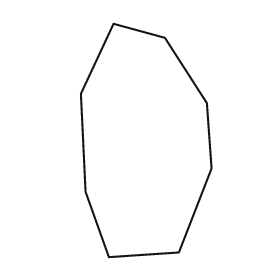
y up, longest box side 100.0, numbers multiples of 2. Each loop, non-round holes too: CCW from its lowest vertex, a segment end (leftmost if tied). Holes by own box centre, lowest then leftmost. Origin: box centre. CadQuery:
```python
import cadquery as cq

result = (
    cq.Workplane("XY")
    .moveTo(-16.0, -50.0)
    .lineTo(14.0, -48.0)
    .lineTo(28.0, -12.0)
    .lineTo(26.0, 16.0)
    .lineTo(8.0, 44.0)
    .lineTo(-14.0, 50.0)
    .lineTo(-28.0, 20.0)
    .lineTo(-26.0, -22.0)
    .close()
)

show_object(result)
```